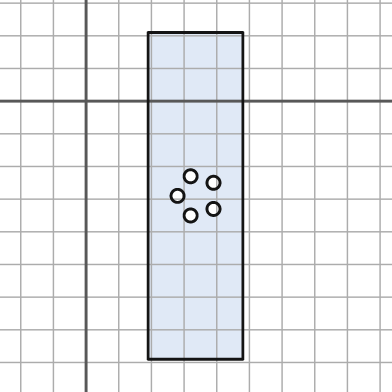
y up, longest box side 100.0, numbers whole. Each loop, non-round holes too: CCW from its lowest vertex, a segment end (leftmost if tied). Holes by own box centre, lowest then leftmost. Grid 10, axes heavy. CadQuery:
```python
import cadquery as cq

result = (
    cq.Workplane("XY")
    .moveTo(19.0, -79.0)
    .lineTo(48.0, -79.0)
    .lineTo(48.0, 21.0)
    .lineTo(19.0, 21.0)
    .close()
    .moveTo(32.0, -35.0)
    .circle(2.0)
    .moveTo(39.0, -33.0)
    .circle(2.0)
    .moveTo(28.0, -29.0)
    .circle(2.0)
    .moveTo(39.0, -25.0)
    .circle(2.0)
    .moveTo(32.0, -23.0)
    .circle(2.0)
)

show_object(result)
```